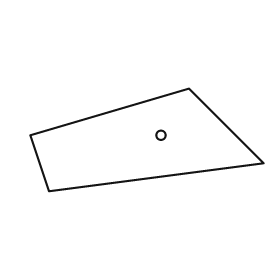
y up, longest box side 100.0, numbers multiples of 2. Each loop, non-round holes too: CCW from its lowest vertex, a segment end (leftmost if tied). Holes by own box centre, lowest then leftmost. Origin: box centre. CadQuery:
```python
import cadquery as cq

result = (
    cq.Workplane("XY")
    .moveTo(-42.0, -22.0)
    .lineTo(50.0, -10.0)
    .lineTo(18.0, 22.0)
    .lineTo(-50.0, 2.0)
    .close()
    .moveTo(6.0, 2.0)
    .circle(2.0)
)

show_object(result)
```